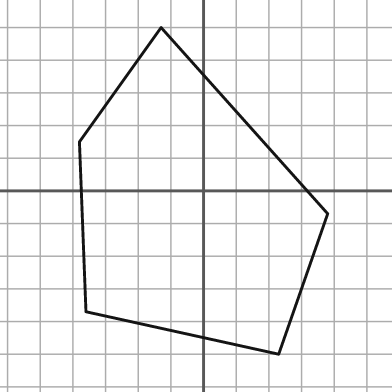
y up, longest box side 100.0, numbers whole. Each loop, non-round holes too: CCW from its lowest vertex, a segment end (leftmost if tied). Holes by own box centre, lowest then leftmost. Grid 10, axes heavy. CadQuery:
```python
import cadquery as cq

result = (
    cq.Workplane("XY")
    .moveTo(23.0, -50.0)
    .lineTo(38.0, -7.0)
    .lineTo(-13.0, 50.0)
    .lineTo(-38.0, 15.0)
    .lineTo(-36.0, -37.0)
    .close()
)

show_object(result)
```